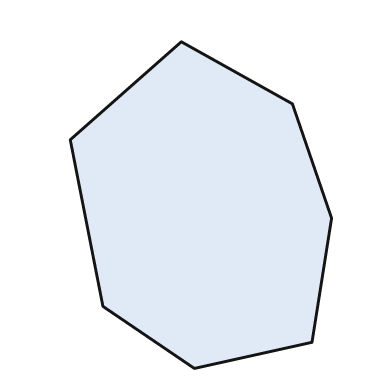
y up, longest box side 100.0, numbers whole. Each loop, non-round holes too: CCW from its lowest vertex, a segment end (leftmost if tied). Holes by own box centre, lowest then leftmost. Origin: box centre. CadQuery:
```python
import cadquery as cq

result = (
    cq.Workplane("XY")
    .moveTo(-2.0, -50.0)
    .lineTo(34.0, -42.0)
    .lineTo(40.0, -4.0)
    .lineTo(28.0, 31.0)
    .lineTo(-6.0, 50.0)
    .lineTo(-40.0, 20.0)
    .lineTo(-30.0, -31.0)
    .close()
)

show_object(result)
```